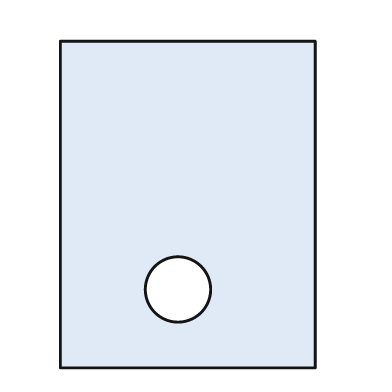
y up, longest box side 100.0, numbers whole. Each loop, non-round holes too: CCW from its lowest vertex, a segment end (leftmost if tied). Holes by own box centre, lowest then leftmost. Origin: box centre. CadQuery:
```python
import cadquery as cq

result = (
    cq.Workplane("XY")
    .moveTo(-39.0, -50.0)
    .lineTo(39.0, -50.0)
    .lineTo(39.0, 50.0)
    .lineTo(-39.0, 50.0)
    .close()
    .moveTo(-3.0, -26.0)
    .circle(10.0)
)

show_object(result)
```